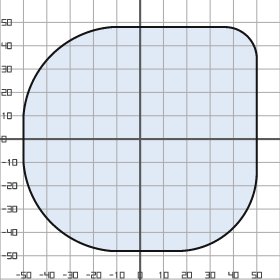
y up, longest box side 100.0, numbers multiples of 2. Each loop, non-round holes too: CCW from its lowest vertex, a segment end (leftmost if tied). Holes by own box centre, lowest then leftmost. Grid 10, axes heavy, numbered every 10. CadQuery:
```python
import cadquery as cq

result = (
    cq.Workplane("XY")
    .moveTo(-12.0, -48.0)
    .lineTo(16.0, -48.0)
    .threePointArc((40.0, -38.0), (50.0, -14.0))
    .lineTo(50.0, 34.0)
    .threePointArc((46.0, 44.0), (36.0, 48.0))
    .lineTo(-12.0, 48.0)
    .threePointArc((-38.0, 36.0), (-50.0, 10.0))
    .lineTo(-50.0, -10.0)
    .threePointArc((-38.0, -36.0), (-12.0, -48.0))
    .close()
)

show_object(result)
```